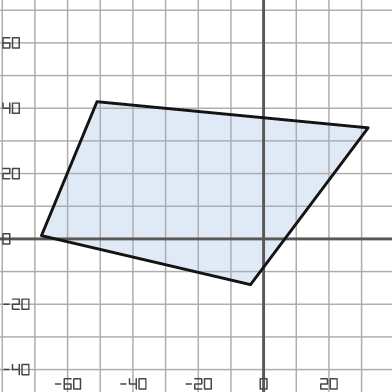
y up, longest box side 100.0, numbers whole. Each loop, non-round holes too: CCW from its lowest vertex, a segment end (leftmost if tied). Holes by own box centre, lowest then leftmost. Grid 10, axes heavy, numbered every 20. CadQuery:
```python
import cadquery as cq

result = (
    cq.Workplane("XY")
    .moveTo(-4.0, -14.0)
    .lineTo(32.0, 34.0)
    .lineTo(-51.0, 42.0)
    .lineTo(-68.0, 1.0)
    .close()
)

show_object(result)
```